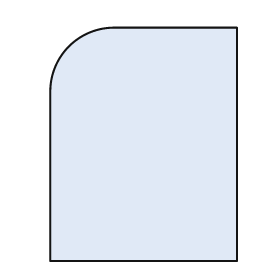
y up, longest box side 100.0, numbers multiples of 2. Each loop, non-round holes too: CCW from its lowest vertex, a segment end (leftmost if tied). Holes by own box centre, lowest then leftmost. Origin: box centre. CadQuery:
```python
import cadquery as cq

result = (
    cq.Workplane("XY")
    .moveTo(-40.0, -50.0)
    .lineTo(40.0, -50.0)
    .lineTo(40.0, 50.0)
    .lineTo(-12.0, 50.0)
    .threePointArc((-32.0, 42.0), (-40.0, 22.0))
    .close()
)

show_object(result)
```